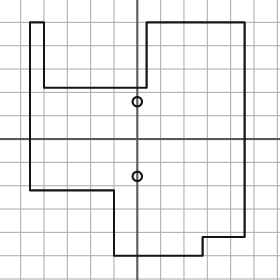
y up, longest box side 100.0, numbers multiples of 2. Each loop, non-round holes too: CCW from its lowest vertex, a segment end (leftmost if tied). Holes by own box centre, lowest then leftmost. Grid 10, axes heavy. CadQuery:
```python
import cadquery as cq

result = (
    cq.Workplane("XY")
    .moveTo(-10.0, -50.0)
    .lineTo(28.0, -50.0)
    .lineTo(28.0, -42.0)
    .lineTo(46.0, -42.0)
    .lineTo(46.0, 50.0)
    .lineTo(4.0, 50.0)
    .lineTo(4.0, 22.0)
    .lineTo(-40.0, 22.0)
    .lineTo(-40.0, 50.0)
    .lineTo(-46.0, 50.0)
    .lineTo(-46.0, -22.0)
    .lineTo(-10.0, -22.0)
    .close()
    .moveTo(0.0, -16.0)
    .circle(2.0)
    .moveTo(0.0, 16.0)
    .circle(2.0)
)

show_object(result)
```